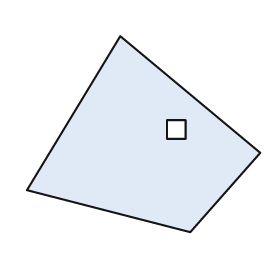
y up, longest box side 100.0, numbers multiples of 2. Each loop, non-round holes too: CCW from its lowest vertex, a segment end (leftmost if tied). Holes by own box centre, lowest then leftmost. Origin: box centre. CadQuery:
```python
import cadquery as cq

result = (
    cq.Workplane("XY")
    .moveTo(20.0, -42.0)
    .lineTo(50.0, -8.0)
    .lineTo(-10.0, 42.0)
    .lineTo(-50.0, -24.0)
    .close()
    .moveTo(10.0, -2.0)
    .lineTo(18.0, -2.0)
    .lineTo(18.0, 6.0)
    .lineTo(10.0, 6.0)
    .close()
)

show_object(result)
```